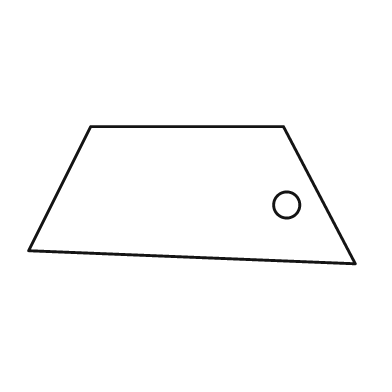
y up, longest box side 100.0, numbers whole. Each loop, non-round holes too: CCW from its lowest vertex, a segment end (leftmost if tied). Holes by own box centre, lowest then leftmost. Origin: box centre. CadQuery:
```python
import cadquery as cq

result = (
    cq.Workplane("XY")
    .moveTo(50.0, -21.0)
    .lineTo(28.0, 21.0)
    .lineTo(-31.0, 21.0)
    .lineTo(-50.0, -17.0)
    .close()
    .moveTo(29.0, -3.0)
    .circle(4.0)
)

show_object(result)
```